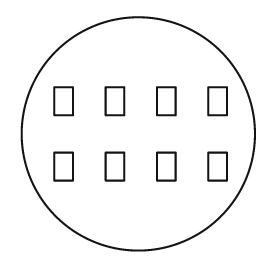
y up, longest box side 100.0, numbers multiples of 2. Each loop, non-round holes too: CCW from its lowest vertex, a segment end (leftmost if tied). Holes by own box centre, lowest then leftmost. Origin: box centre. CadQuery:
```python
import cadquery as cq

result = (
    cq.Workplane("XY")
    .moveTo(0.0, 0.0)
    .circle(50.0)
    .moveTo(-36.0, -20.0)
    .lineTo(-28.0, -20.0)
    .lineTo(-28.0, -8.0)
    .lineTo(-36.0, -8.0)
    .close()
    .moveTo(-14.0, -20.0)
    .lineTo(-6.0, -20.0)
    .lineTo(-6.0, -8.0)
    .lineTo(-14.0, -8.0)
    .close()
    .moveTo(8.0, -20.0)
    .lineTo(16.0, -20.0)
    .lineTo(16.0, -8.0)
    .lineTo(8.0, -8.0)
    .close()
    .moveTo(30.0, -20.0)
    .lineTo(38.0, -20.0)
    .lineTo(38.0, -8.0)
    .lineTo(30.0, -8.0)
    .close()
    .moveTo(-36.0, 8.0)
    .lineTo(-28.0, 8.0)
    .lineTo(-28.0, 20.0)
    .lineTo(-36.0, 20.0)
    .close()
    .moveTo(-14.0, 8.0)
    .lineTo(-6.0, 8.0)
    .lineTo(-6.0, 20.0)
    .lineTo(-14.0, 20.0)
    .close()
    .moveTo(8.0, 8.0)
    .lineTo(16.0, 8.0)
    .lineTo(16.0, 20.0)
    .lineTo(8.0, 20.0)
    .close()
    .moveTo(30.0, 8.0)
    .lineTo(38.0, 8.0)
    .lineTo(38.0, 20.0)
    .lineTo(30.0, 20.0)
    .close()
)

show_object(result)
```